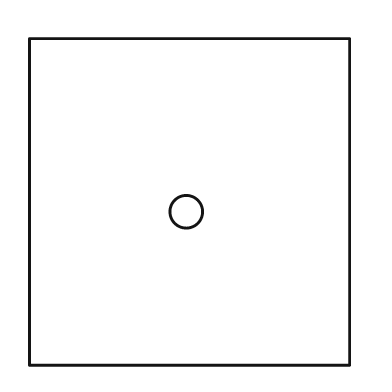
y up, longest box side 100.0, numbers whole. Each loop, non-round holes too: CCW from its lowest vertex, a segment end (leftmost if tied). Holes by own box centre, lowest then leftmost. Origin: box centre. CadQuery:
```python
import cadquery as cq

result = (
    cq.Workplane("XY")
    .moveTo(-49.0, -50.0)
    .lineTo(49.0, -50.0)
    .lineTo(49.0, 50.0)
    .lineTo(-49.0, 50.0)
    .close()
    .moveTo(-1.0, -3.0)
    .circle(5.0)
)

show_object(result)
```